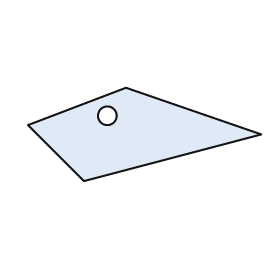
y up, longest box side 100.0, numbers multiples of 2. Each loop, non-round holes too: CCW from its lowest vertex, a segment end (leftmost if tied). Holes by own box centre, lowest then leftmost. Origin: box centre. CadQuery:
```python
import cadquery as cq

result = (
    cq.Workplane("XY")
    .moveTo(-26.0, -20.0)
    .lineTo(50.0, 0.0)
    .lineTo(-8.0, 20.0)
    .lineTo(-50.0, 4.0)
    .close()
    .moveTo(-16.0, 8.0)
    .circle(4.0)
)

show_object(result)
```